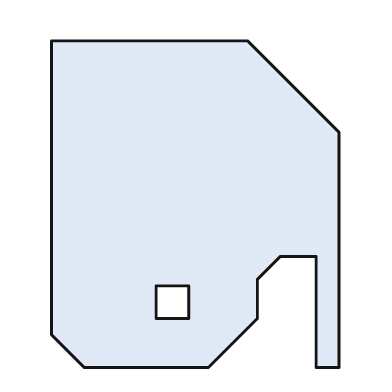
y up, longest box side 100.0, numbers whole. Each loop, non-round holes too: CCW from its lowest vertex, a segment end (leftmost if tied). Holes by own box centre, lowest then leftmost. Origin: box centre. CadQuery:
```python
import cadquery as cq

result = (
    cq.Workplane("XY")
    .moveTo(-34.0, -50.0)
    .lineTo(4.0, -50.0)
    .lineTo(19.0, -35.0)
    .lineTo(19.0, -23.0)
    .lineTo(26.0, -16.0)
    .lineTo(37.0, -16.0)
    .lineTo(37.0, -50.0)
    .lineTo(44.0, -50.0)
    .lineTo(44.0, 22.0)
    .lineTo(16.0, 50.0)
    .lineTo(-44.0, 50.0)
    .lineTo(-44.0, -40.0)
    .close()
    .moveTo(-12.0, -35.0)
    .lineTo(-2.0, -35.0)
    .lineTo(-2.0, -25.0)
    .lineTo(-12.0, -25.0)
    .close()
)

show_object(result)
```